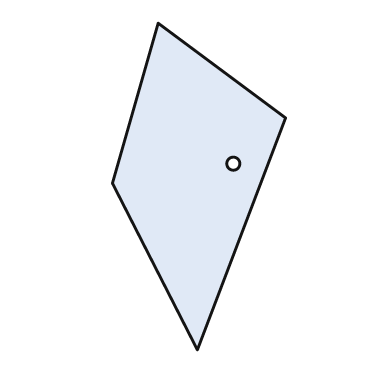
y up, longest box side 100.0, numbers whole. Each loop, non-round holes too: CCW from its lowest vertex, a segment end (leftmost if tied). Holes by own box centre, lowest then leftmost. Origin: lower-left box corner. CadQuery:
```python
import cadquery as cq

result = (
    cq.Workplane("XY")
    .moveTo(26.0, 0.0)
    .lineTo(53.0, 71.0)
    .lineTo(14.0, 100.0)
    .lineTo(0.0, 51.0)
    .close()
    .moveTo(37.0, 57.0)
    .circle(2.0)
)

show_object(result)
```